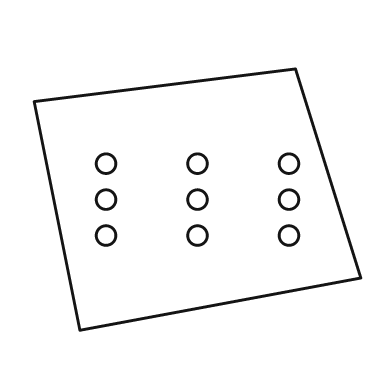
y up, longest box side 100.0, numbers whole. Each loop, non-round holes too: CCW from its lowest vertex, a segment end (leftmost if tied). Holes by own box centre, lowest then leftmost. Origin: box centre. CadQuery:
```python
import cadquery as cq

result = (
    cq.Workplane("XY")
    .moveTo(-36.0, -40.0)
    .lineTo(50.0, -24.0)
    .lineTo(30.0, 40.0)
    .lineTo(-50.0, 30.0)
    .close()
    .moveTo(-28.0, -11.0)
    .circle(3.0)
    .moveTo(0.0, -11.0)
    .circle(3.0)
    .moveTo(28.0, -11.0)
    .circle(3.0)
    .moveTo(-28.0, 0.0)
    .circle(3.0)
    .moveTo(0.0, 0.0)
    .circle(3.0)
    .moveTo(28.0, 0.0)
    .circle(3.0)
    .moveTo(-28.0, 11.0)
    .circle(3.0)
    .moveTo(0.0, 11.0)
    .circle(3.0)
    .moveTo(28.0, 11.0)
    .circle(3.0)
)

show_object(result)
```